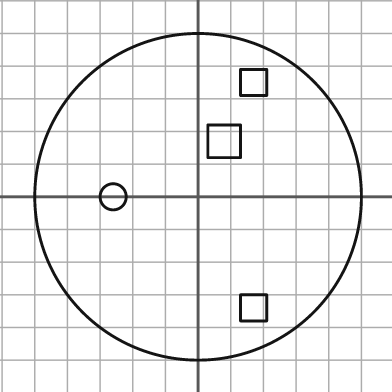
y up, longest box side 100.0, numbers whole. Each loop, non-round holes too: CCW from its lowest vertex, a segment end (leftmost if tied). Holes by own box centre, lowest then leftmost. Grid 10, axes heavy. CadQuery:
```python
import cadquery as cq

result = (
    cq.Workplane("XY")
    .moveTo(0.0, 0.0)
    .circle(50.0)
    .moveTo(13.0, -38.0)
    .lineTo(21.0, -38.0)
    .lineTo(21.0, -30.0)
    .lineTo(13.0, -30.0)
    .close()
    .moveTo(-26.0, 0.0)
    .circle(4.0)
    .moveTo(3.0, 12.0)
    .lineTo(13.0, 12.0)
    .lineTo(13.0, 22.0)
    .lineTo(3.0, 22.0)
    .close()
    .moveTo(13.0, 31.0)
    .lineTo(21.0, 31.0)
    .lineTo(21.0, 39.0)
    .lineTo(13.0, 39.0)
    .close()
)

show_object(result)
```